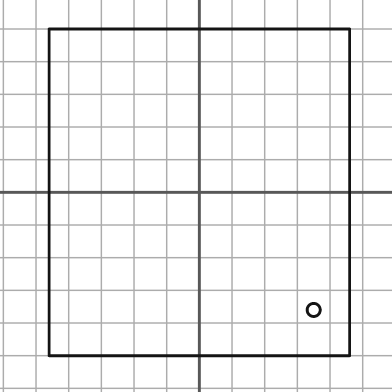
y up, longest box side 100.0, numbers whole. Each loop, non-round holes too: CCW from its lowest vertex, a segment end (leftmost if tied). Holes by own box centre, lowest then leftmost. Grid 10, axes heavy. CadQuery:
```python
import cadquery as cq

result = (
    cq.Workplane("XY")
    .moveTo(-46.0, -50.0)
    .lineTo(46.0, -50.0)
    .lineTo(46.0, 50.0)
    .lineTo(-46.0, 50.0)
    .close()
    .moveTo(35.0, -36.0)
    .circle(2.0)
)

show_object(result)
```